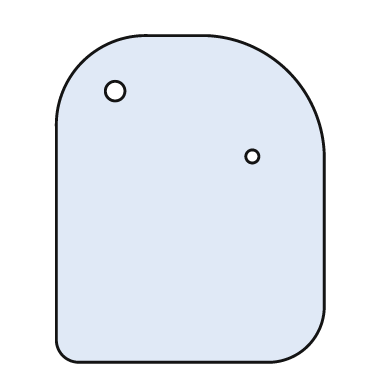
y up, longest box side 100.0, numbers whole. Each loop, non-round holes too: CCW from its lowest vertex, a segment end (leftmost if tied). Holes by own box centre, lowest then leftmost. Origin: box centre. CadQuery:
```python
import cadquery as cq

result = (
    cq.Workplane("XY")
    .moveTo(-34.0, -50.0)
    .lineTo(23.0, -50.0)
    .threePointArc((36.0, -45.0), (41.0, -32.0))
    .lineTo(41.0, 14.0)
    .threePointArc((30.0, 39.0), (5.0, 50.0))
    .lineTo(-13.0, 50.0)
    .threePointArc((-33.0, 42.0), (-41.0, 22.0))
    .lineTo(-41.0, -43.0)
    .threePointArc((-39.0, -48.0), (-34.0, -50.0))
    .close()
    .moveTo(19.0, 13.0)
    .circle(2.0)
    .moveTo(-23.0, 33.0)
    .circle(3.0)
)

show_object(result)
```